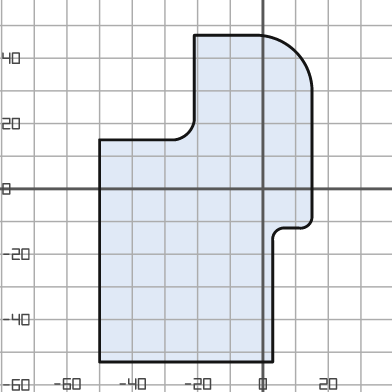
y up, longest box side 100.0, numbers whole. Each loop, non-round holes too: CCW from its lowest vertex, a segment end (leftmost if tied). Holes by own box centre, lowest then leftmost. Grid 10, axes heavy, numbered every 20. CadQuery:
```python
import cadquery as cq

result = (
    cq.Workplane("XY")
    .moveTo(-50.0, -53.0)
    .lineTo(3.0, -53.0)
    .lineTo(3.0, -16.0)
    .threePointArc((4.0, -13.0), (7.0, -12.0))
    .lineTo(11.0, -12.0)
    .threePointArc((14.0, -11.0), (15.0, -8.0))
    .lineTo(15.0, 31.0)
    .threePointArc((10.0, 42.0), (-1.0, 47.0))
    .lineTo(-21.0, 47.0)
    .lineTo(-21.0, 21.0)
    .threePointArc((-23.0, 17.0), (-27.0, 15.0))
    .lineTo(-50.0, 15.0)
    .close()
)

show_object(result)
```